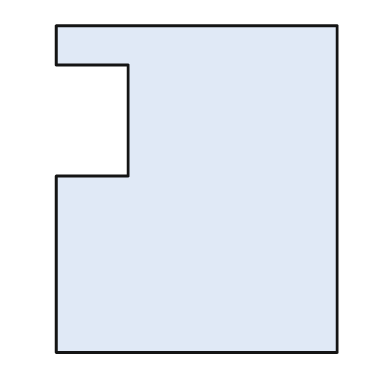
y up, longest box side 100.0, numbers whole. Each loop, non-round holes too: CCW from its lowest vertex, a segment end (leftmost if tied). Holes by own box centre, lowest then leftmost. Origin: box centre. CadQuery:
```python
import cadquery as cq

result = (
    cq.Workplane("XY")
    .moveTo(-43.0, -50.0)
    .lineTo(43.0, -50.0)
    .lineTo(43.0, 50.0)
    .lineTo(-43.0, 50.0)
    .lineTo(-43.0, 38.0)
    .lineTo(-21.0, 38.0)
    .lineTo(-21.0, 4.0)
    .lineTo(-43.0, 4.0)
    .close()
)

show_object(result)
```